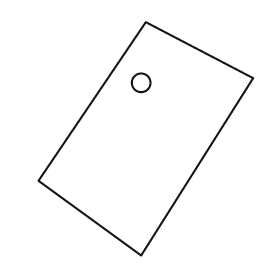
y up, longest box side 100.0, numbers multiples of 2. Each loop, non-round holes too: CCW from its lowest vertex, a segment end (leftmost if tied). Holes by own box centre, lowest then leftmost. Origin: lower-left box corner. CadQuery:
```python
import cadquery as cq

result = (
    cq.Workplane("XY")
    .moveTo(44.0, 0.0)
    .lineTo(92.0, 76.0)
    .lineTo(46.0, 100.0)
    .lineTo(0.0, 32.0)
    .close()
    .moveTo(44.0, 74.0)
    .circle(4.0)
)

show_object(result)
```